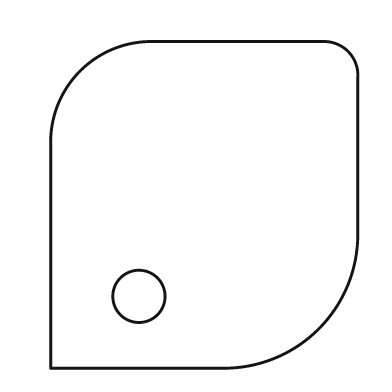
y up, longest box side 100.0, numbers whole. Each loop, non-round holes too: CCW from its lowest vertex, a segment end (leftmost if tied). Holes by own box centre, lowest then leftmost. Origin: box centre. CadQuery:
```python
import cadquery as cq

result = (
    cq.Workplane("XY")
    .moveTo(-47.0, -50.0)
    .lineTo(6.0, -50.0)
    .threePointArc((35.0, -38.0), (47.0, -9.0))
    .lineTo(47.0, 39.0)
    .threePointArc((44.0, 47.0), (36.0, 50.0))
    .lineTo(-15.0, 50.0)
    .threePointArc((-38.0, 41.0), (-47.0, 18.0))
    .close()
    .moveTo(-20.0, -28.0)
    .circle(8.0)
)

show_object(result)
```